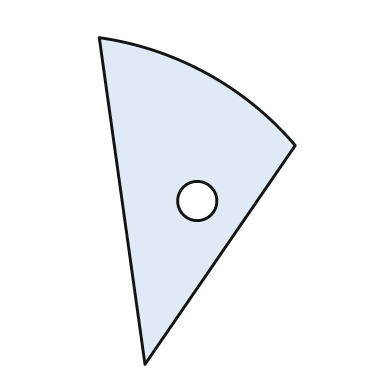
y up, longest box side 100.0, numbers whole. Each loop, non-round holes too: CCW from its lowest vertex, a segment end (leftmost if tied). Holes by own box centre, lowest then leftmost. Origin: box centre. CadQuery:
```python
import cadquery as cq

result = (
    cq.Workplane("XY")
    .moveTo(-16.0, -50.0)
    .lineTo(30.0, 17.0)
    .threePointArc((3.0, 39.0), (-30.0, 50.0))
    .close()
    .moveTo(0.0, 0.0)
    .circle(6.0)
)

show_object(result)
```